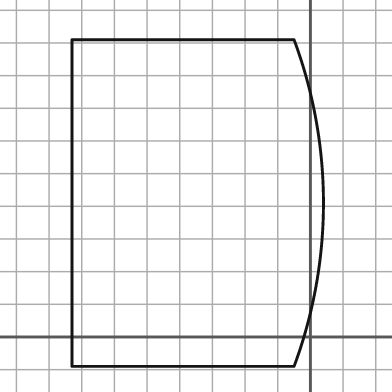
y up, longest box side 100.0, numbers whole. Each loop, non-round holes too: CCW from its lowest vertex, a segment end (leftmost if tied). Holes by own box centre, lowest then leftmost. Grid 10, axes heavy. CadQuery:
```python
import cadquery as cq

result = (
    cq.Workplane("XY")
    .moveTo(-73.0, -9.0)
    .lineTo(-5.0, -9.0)
    .threePointArc((4.0, 41.0), (-5.0, 91.0))
    .lineTo(-73.0, 91.0)
    .close()
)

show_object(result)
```